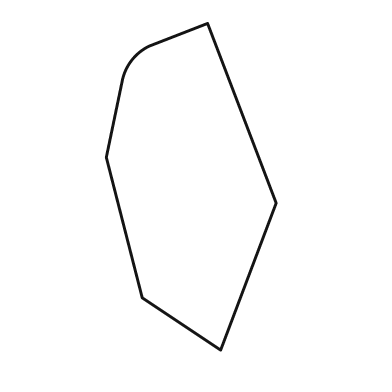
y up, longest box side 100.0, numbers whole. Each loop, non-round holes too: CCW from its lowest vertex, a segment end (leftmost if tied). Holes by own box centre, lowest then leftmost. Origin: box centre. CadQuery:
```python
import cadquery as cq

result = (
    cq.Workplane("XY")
    .moveTo(9.0, -50.0)
    .lineTo(26.0, -5.0)
    .lineTo(5.0, 50.0)
    .lineTo(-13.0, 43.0)
    .threePointArc((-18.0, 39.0), (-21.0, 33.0))
    .lineTo(-26.0, 9.0)
    .lineTo(-15.0, -34.0)
    .close()
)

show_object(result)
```